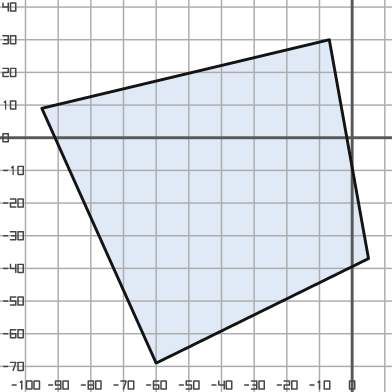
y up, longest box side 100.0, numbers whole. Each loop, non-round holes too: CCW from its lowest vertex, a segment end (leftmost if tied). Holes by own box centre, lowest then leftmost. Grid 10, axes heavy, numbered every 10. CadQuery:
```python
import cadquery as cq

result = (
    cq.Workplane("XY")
    .moveTo(-60.0, -69.0)
    .lineTo(5.0, -37.0)
    .lineTo(-7.0, 30.0)
    .lineTo(-95.0, 9.0)
    .close()
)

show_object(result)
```